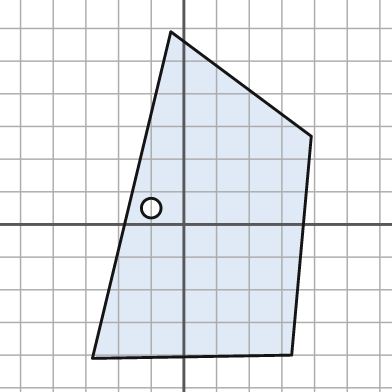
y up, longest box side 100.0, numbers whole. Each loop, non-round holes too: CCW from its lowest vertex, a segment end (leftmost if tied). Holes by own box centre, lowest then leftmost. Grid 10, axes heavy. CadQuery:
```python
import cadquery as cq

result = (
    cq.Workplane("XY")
    .moveTo(-28.0, -41.0)
    .lineTo(33.0, -40.0)
    .lineTo(39.0, 27.0)
    .lineTo(-4.0, 59.0)
    .close()
    .moveTo(-10.0, 5.0)
    .circle(3.0)
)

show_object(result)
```